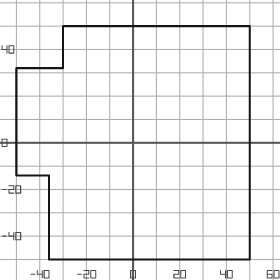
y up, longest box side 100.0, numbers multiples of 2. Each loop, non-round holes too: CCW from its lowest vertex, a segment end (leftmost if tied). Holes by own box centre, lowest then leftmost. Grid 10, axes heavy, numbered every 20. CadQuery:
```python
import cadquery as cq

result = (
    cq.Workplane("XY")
    .moveTo(-36.0, -50.0)
    .lineTo(50.0, -50.0)
    .lineTo(50.0, 50.0)
    .lineTo(-30.0, 50.0)
    .lineTo(-30.0, 32.0)
    .lineTo(-50.0, 32.0)
    .lineTo(-50.0, -14.0)
    .lineTo(-36.0, -14.0)
    .close()
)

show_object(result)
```